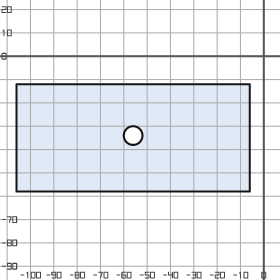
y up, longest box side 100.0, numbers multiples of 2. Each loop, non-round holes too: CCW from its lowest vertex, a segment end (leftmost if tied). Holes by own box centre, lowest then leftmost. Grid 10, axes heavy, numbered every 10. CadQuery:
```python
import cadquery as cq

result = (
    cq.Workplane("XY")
    .moveTo(-106.0, -58.0)
    .lineTo(-6.0, -58.0)
    .lineTo(-6.0, -12.0)
    .lineTo(-106.0, -12.0)
    .close()
    .moveTo(-56.0, -34.0)
    .circle(4.0)
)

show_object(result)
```